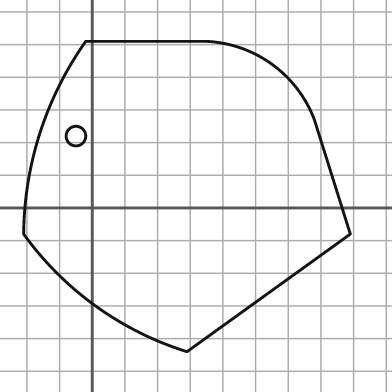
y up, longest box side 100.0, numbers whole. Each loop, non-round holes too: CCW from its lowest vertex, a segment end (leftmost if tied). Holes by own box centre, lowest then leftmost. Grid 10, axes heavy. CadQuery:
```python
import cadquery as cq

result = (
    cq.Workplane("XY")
    .moveTo(29.0, -44.0)
    .lineTo(79.0, -8.0)
    .lineTo(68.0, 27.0)
    .threePointArc((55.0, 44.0), (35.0, 51.0))
    .lineTo(-2.0, 51.0)
    .threePointArc((-16.0, 23.0), (-21.0, -8.0))
    .threePointArc((1.0, -30.0), (29.0, -44.0))
    .close()
    .moveTo(-5.0, 22.0)
    .circle(3.0)
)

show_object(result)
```